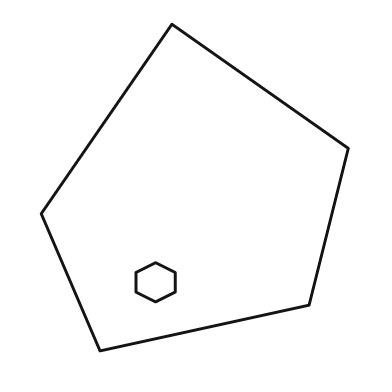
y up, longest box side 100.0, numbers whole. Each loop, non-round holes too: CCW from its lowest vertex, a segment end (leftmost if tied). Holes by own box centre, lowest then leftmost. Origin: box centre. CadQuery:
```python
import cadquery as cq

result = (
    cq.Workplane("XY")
    .moveTo(-29.0, -50.0)
    .lineTo(35.0, -36.0)
    .lineTo(47.0, 12.0)
    .lineTo(-7.0, 50.0)
    .lineTo(-47.0, -8.0)
    .close()
    .moveTo(-12.0, -35.0)
    .lineTo(-6.0, -32.0)
    .lineTo(-6.0, -26.0)
    .lineTo(-12.0, -23.0)
    .lineTo(-18.0, -26.0)
    .lineTo(-18.0, -32.0)
    .close()
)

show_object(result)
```